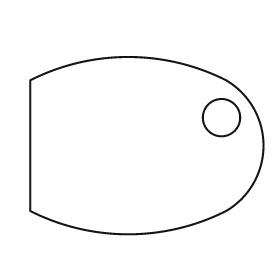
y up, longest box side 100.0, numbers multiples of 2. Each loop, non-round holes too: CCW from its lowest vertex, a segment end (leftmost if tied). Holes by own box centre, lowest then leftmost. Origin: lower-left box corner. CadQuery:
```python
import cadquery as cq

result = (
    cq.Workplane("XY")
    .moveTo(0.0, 10.0)
    .threePointArc((42.0, 0.0), (84.0, 10.0))
    .threePointArc((100.0, 38.0), (84.0, 66.0))
    .threePointArc((42.0, 76.0), (0.0, 66.0))
    .close()
    .moveTo(82.0, 50.0)
    .circle(8.0)
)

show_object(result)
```